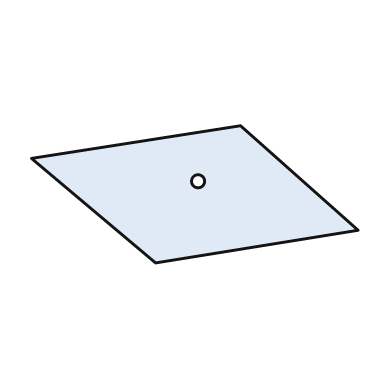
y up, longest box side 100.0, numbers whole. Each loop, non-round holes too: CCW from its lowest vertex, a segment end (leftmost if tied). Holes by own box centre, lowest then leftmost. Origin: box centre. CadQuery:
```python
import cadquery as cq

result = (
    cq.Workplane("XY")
    .moveTo(-12.0, -21.0)
    .lineTo(50.0, -11.0)
    .lineTo(14.0, 21.0)
    .lineTo(-50.0, 11.0)
    .close()
    .moveTo(1.0, 4.0)
    .circle(2.0)
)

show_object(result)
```